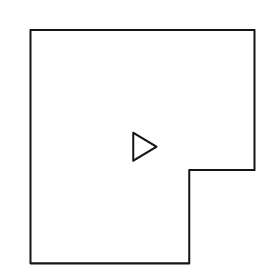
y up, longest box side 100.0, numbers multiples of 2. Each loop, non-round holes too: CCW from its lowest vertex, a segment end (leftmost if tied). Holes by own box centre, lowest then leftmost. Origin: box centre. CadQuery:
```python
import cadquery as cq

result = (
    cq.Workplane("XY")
    .moveTo(-48.0, -50.0)
    .lineTo(20.0, -50.0)
    .lineTo(20.0, -10.0)
    .lineTo(48.0, -10.0)
    .lineTo(48.0, 50.0)
    .lineTo(-48.0, 50.0)
    .close()
    .moveTo(-4.0, -6.0)
    .lineTo(6.0, 0.0)
    .lineTo(-4.0, 6.0)
    .close()
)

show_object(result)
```